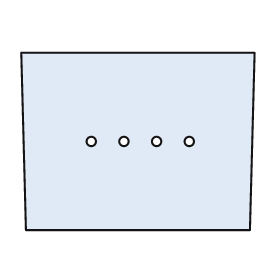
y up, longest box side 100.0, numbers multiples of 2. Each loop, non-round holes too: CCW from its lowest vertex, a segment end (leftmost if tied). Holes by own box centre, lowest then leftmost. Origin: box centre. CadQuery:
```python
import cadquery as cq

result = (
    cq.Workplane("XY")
    .moveTo(-48.0, -38.0)
    .lineTo(48.0, -38.0)
    .lineTo(50.0, 38.0)
    .lineTo(-50.0, 38.0)
    .close()
    .moveTo(-20.0, 0.0)
    .circle(2.0)
    .moveTo(-6.0, 0.0)
    .circle(2.0)
    .moveTo(8.0, 0.0)
    .circle(2.0)
    .moveTo(22.0, 0.0)
    .circle(2.0)
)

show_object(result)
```